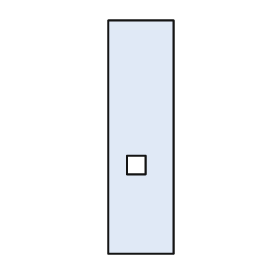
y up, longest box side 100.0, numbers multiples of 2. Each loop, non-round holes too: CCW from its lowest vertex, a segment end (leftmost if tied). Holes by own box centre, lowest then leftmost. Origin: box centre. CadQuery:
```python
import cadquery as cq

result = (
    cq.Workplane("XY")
    .moveTo(-14.0, -50.0)
    .lineTo(14.0, -50.0)
    .lineTo(14.0, 50.0)
    .lineTo(-14.0, 50.0)
    .close()
    .moveTo(-6.0, -16.0)
    .lineTo(2.0, -16.0)
    .lineTo(2.0, -8.0)
    .lineTo(-6.0, -8.0)
    .close()
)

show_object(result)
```